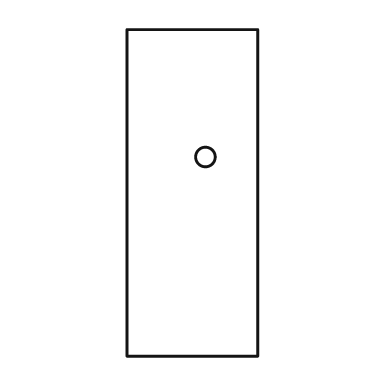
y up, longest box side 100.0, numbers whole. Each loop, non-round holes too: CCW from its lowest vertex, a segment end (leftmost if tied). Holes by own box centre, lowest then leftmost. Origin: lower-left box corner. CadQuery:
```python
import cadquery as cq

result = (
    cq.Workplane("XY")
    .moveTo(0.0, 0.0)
    .lineTo(40.0, 0.0)
    .lineTo(40.0, 100.0)
    .lineTo(0.0, 100.0)
    .close()
    .moveTo(24.0, 61.0)
    .circle(3.0)
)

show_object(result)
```